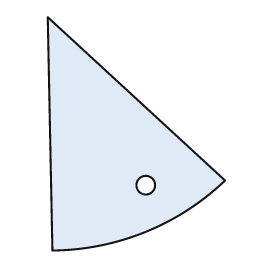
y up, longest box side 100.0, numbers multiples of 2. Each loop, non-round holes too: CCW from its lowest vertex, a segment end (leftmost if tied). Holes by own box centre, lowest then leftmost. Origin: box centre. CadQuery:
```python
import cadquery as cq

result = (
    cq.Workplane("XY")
    .moveTo(-36.0, -50.0)
    .threePointArc((4.0, -42.0), (38.0, -20.0))
    .lineTo(-38.0, 50.0)
    .close()
    .moveTo(4.0, -22.0)
    .circle(4.0)
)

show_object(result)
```